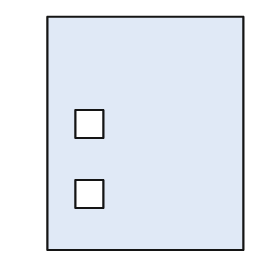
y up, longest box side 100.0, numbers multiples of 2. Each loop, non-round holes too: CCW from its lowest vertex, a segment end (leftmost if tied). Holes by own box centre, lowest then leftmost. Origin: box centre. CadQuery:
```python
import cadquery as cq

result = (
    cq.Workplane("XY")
    .moveTo(-42.0, -50.0)
    .lineTo(42.0, -50.0)
    .lineTo(42.0, 50.0)
    .lineTo(-42.0, 50.0)
    .close()
    .moveTo(-30.0, -32.0)
    .lineTo(-18.0, -32.0)
    .lineTo(-18.0, -20.0)
    .lineTo(-30.0, -20.0)
    .close()
    .moveTo(-30.0, -2.0)
    .lineTo(-18.0, -2.0)
    .lineTo(-18.0, 10.0)
    .lineTo(-30.0, 10.0)
    .close()
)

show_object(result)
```